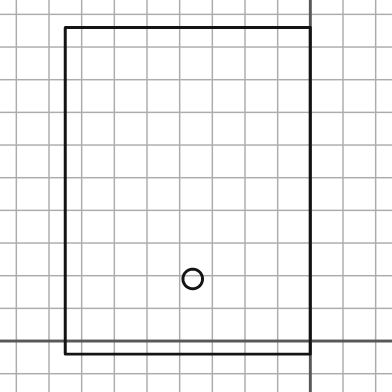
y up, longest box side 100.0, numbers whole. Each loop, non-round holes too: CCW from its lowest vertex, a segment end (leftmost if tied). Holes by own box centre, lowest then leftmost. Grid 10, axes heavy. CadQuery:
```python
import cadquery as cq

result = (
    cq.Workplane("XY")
    .moveTo(-75.0, -4.0)
    .lineTo(0.0, -4.0)
    .lineTo(0.0, 96.0)
    .lineTo(-75.0, 96.0)
    .close()
    .moveTo(-36.0, 19.0)
    .circle(3.0)
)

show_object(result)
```